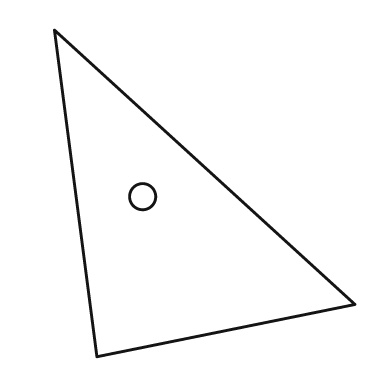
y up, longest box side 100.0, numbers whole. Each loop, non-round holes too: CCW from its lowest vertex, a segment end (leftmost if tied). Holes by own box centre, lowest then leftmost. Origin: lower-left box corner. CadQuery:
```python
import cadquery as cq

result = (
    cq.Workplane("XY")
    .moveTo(13.0, 0.0)
    .lineTo(92.0, 16.0)
    .lineTo(0.0, 100.0)
    .close()
    .moveTo(27.0, 49.0)
    .circle(4.0)
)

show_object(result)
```